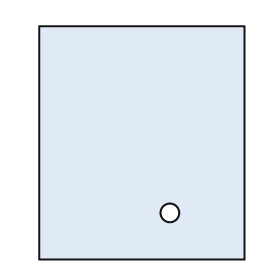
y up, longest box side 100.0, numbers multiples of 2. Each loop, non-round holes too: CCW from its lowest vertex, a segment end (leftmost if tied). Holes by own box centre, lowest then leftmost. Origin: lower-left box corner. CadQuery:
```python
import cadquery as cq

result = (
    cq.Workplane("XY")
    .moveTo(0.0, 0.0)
    .lineTo(88.0, 0.0)
    .lineTo(88.0, 100.0)
    .lineTo(0.0, 100.0)
    .close()
    .moveTo(56.0, 20.0)
    .circle(4.0)
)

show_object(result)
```